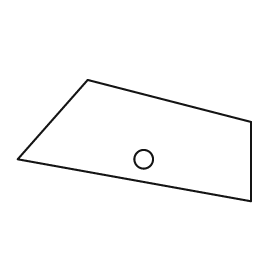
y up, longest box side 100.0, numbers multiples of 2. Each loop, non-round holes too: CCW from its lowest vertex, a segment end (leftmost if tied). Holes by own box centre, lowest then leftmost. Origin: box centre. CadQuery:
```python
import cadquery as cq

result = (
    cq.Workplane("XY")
    .moveTo(50.0, -26.0)
    .lineTo(50.0, 8.0)
    .lineTo(-20.0, 26.0)
    .lineTo(-50.0, -8.0)
    .close()
    .moveTo(4.0, -8.0)
    .circle(4.0)
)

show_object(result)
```